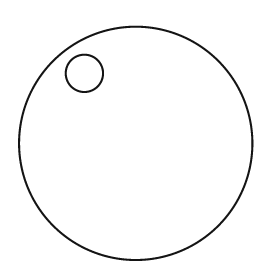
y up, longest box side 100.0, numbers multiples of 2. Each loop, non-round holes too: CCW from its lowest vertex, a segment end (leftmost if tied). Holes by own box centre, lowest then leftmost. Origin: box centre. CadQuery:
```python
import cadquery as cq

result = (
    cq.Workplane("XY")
    .moveTo(0.0, 0.0)
    .circle(50.0)
    .moveTo(-22.0, 30.0)
    .circle(8.0)
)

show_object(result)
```